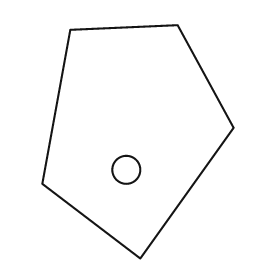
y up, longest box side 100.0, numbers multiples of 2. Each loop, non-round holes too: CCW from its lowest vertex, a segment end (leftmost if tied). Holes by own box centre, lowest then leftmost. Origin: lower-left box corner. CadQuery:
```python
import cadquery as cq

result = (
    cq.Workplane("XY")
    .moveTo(42.0, 0.0)
    .lineTo(82.0, 56.0)
    .lineTo(58.0, 100.0)
    .lineTo(12.0, 98.0)
    .lineTo(0.0, 32.0)
    .close()
    .moveTo(36.0, 38.0)
    .circle(6.0)
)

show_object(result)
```